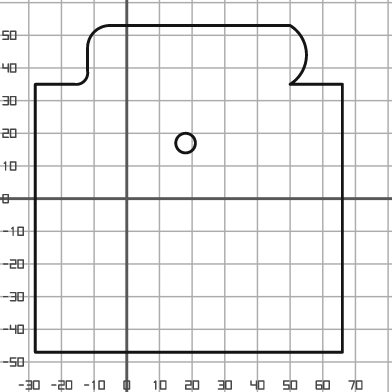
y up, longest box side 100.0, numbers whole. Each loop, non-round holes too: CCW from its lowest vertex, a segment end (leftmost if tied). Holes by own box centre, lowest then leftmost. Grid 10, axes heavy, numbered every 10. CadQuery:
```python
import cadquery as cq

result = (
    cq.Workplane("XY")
    .moveTo(-28.0, -47.0)
    .lineTo(66.0, -47.0)
    .lineTo(66.0, 35.0)
    .lineTo(50.0, 35.0)
    .threePointArc((55.0, 44.0), (50.0, 53.0))
    .lineTo(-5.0, 53.0)
    .threePointArc((-10.0, 51.0), (-12.0, 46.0))
    .lineTo(-12.0, 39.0)
    .threePointArc((-13.0, 36.0), (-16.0, 35.0))
    .lineTo(-28.0, 35.0)
    .close()
    .moveTo(18.0, 17.0)
    .circle(3.0)
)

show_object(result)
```